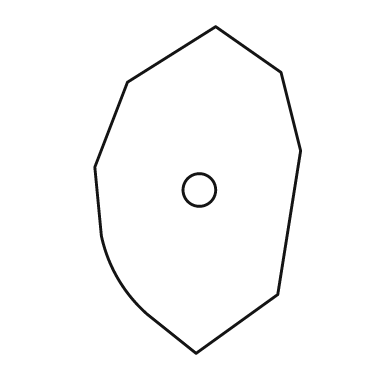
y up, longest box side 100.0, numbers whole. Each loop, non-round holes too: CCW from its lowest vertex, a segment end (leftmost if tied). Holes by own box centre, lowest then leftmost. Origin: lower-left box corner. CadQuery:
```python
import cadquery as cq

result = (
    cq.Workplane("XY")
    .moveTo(31.0, 0.0)
    .lineTo(56.0, 18.0)
    .lineTo(63.0, 62.0)
    .lineTo(57.0, 86.0)
    .lineTo(37.0, 100.0)
    .lineTo(10.0, 83.0)
    .lineTo(0.0, 57.0)
    .lineTo(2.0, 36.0)
    .threePointArc((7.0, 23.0), (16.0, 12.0))
    .close()
    .moveTo(32.0, 50.0)
    .circle(5.0)
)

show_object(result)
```